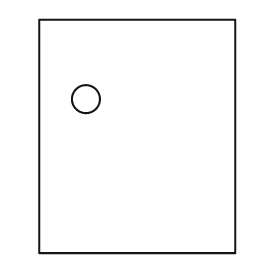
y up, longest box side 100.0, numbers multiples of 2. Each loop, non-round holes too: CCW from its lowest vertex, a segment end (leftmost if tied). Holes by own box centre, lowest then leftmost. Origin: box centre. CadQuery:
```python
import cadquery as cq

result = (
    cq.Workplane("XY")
    .moveTo(-42.0, -50.0)
    .lineTo(42.0, -50.0)
    .lineTo(42.0, 50.0)
    .lineTo(-42.0, 50.0)
    .close()
    .moveTo(-22.0, 16.0)
    .circle(6.0)
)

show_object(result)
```